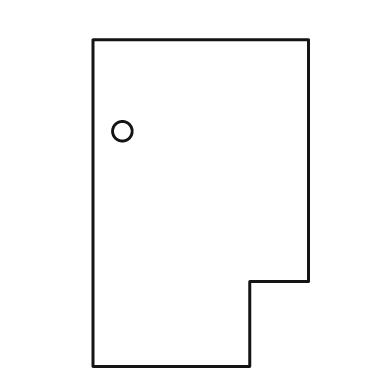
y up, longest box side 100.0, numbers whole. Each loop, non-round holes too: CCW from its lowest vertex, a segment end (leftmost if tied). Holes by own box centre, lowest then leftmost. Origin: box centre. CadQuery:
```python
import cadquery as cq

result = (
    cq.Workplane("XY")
    .moveTo(-33.0, -50.0)
    .lineTo(15.0, -50.0)
    .lineTo(15.0, -24.0)
    .lineTo(33.0, -24.0)
    .lineTo(33.0, 50.0)
    .lineTo(-33.0, 50.0)
    .close()
    .moveTo(-24.0, 22.0)
    .circle(3.0)
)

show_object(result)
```